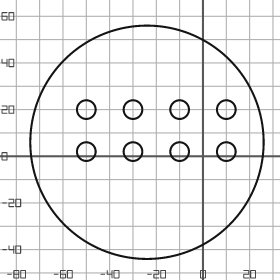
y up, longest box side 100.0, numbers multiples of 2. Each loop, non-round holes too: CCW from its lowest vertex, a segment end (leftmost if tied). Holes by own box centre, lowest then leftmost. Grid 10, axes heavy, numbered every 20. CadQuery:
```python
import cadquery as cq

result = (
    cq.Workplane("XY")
    .moveTo(-24.0, 6.0)
    .circle(50.0)
    .moveTo(-50.0, 2.0)
    .circle(4.0)
    .moveTo(-30.0, 2.0)
    .circle(4.0)
    .moveTo(-10.0, 2.0)
    .circle(4.0)
    .moveTo(10.0, 2.0)
    .circle(4.0)
    .moveTo(-50.0, 20.0)
    .circle(4.0)
    .moveTo(-30.0, 20.0)
    .circle(4.0)
    .moveTo(-10.0, 20.0)
    .circle(4.0)
    .moveTo(10.0, 20.0)
    .circle(4.0)
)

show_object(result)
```